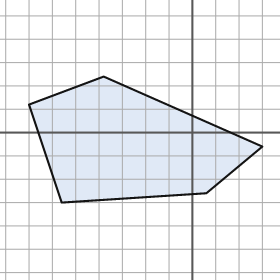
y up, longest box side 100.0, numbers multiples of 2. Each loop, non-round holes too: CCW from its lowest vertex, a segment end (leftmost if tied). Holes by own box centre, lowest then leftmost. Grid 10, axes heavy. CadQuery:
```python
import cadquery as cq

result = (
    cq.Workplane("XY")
    .moveTo(-56.0, -30.0)
    .lineTo(6.0, -26.0)
    .lineTo(30.0, -6.0)
    .lineTo(-38.0, 24.0)
    .lineTo(-70.0, 12.0)
    .close()
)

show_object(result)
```